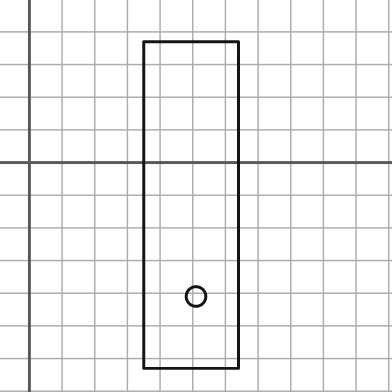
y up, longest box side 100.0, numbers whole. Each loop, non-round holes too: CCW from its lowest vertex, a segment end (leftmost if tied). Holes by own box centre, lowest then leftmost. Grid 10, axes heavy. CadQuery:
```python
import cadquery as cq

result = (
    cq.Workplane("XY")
    .moveTo(35.0, -63.0)
    .lineTo(64.0, -63.0)
    .lineTo(64.0, 37.0)
    .lineTo(35.0, 37.0)
    .close()
    .moveTo(51.0, -41.0)
    .circle(3.0)
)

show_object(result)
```